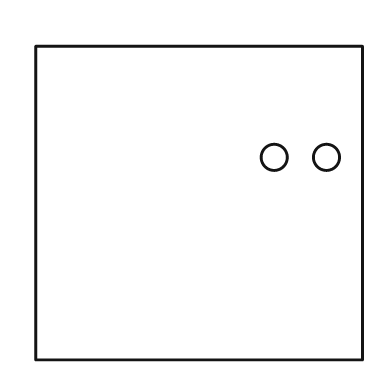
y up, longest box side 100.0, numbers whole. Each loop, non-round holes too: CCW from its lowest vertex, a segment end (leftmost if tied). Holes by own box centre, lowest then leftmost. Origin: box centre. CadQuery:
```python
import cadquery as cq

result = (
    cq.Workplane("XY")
    .moveTo(-50.0, -48.0)
    .lineTo(50.0, -48.0)
    .lineTo(50.0, 48.0)
    .lineTo(-50.0, 48.0)
    .close()
    .moveTo(23.0, 14.0)
    .circle(4.0)
    .moveTo(39.0, 14.0)
    .circle(4.0)
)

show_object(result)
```